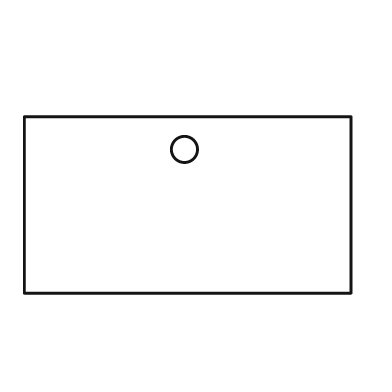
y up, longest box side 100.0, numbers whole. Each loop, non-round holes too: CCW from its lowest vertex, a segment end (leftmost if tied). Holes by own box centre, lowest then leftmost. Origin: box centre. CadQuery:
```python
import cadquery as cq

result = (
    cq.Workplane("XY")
    .moveTo(-50.0, -27.0)
    .lineTo(50.0, -27.0)
    .lineTo(50.0, 27.0)
    .lineTo(-50.0, 27.0)
    .close()
    .moveTo(-1.0, 17.0)
    .circle(4.0)
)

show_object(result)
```